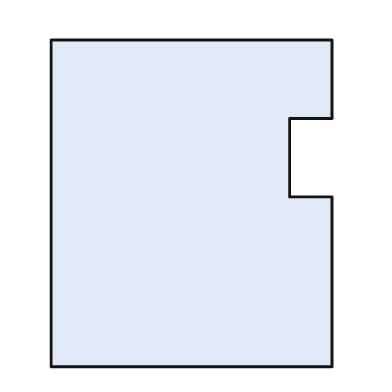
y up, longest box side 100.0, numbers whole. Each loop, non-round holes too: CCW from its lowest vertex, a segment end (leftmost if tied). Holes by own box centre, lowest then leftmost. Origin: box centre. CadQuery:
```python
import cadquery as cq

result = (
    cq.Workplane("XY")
    .moveTo(-43.0, -50.0)
    .lineTo(43.0, -50.0)
    .lineTo(43.0, 2.0)
    .lineTo(30.0, 2.0)
    .lineTo(30.0, 26.0)
    .lineTo(43.0, 26.0)
    .lineTo(43.0, 50.0)
    .lineTo(-43.0, 50.0)
    .close()
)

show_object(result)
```